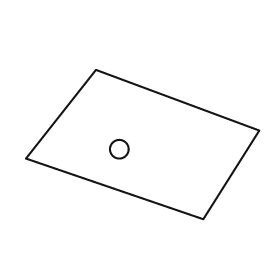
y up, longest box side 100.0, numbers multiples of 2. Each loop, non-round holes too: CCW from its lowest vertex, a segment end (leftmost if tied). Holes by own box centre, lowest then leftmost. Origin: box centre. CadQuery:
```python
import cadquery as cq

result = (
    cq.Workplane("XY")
    .moveTo(26.0, -32.0)
    .lineTo(50.0, 6.0)
    .lineTo(-20.0, 32.0)
    .lineTo(-50.0, -6.0)
    .close()
    .moveTo(-10.0, -2.0)
    .circle(4.0)
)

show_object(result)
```